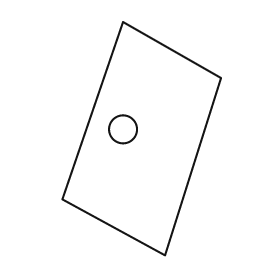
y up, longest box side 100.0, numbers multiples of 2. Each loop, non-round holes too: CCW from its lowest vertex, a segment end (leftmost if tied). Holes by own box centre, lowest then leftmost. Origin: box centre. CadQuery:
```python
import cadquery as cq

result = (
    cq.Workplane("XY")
    .moveTo(10.0, -50.0)
    .lineTo(34.0, 26.0)
    .lineTo(-8.0, 50.0)
    .lineTo(-34.0, -26.0)
    .close()
    .moveTo(-8.0, 4.0)
    .circle(6.0)
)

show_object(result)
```